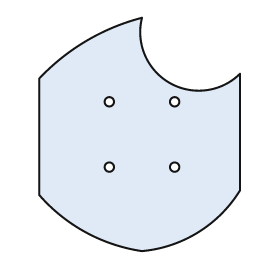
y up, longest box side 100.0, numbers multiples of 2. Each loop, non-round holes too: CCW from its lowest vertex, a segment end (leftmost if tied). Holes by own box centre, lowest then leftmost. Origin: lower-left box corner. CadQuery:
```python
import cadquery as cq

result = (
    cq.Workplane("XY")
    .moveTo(44.0, 0.0)
    .threePointArc((68.0, 8.0), (86.0, 26.0))
    .lineTo(86.0, 76.0)
    .threePointArc((56.0, 72.0), (44.0, 100.0))
    .threePointArc((20.0, 90.0), (0.0, 74.0))
    .lineTo(0.0, 24.0)
    .threePointArc((20.0, 8.0), (44.0, 0.0))
    .close()
    .moveTo(30.0, 36.0)
    .circle(2.0)
    .moveTo(58.0, 36.0)
    .circle(2.0)
    .moveTo(30.0, 64.0)
    .circle(2.0)
    .moveTo(58.0, 64.0)
    .circle(2.0)
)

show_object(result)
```